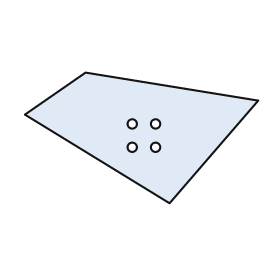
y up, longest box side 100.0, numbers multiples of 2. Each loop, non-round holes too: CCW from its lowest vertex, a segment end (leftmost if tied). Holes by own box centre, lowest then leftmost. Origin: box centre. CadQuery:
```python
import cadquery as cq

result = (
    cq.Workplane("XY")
    .moveTo(12.0, -28.0)
    .lineTo(50.0, 16.0)
    .lineTo(-24.0, 28.0)
    .lineTo(-50.0, 10.0)
    .close()
    .moveTo(-4.0, -4.0)
    .circle(2.0)
    .moveTo(6.0, -4.0)
    .circle(2.0)
    .moveTo(-4.0, 6.0)
    .circle(2.0)
    .moveTo(6.0, 6.0)
    .circle(2.0)
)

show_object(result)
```